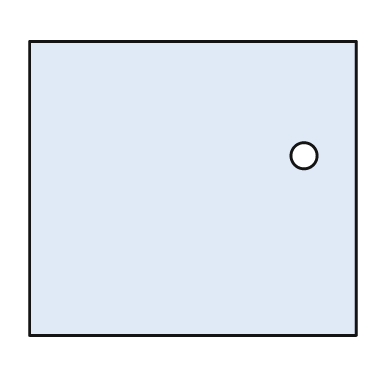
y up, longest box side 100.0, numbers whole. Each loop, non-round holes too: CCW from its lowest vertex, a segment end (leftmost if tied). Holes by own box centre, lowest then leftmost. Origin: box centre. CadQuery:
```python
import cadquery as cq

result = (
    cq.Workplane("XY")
    .moveTo(-50.0, -45.0)
    .lineTo(50.0, -45.0)
    .lineTo(50.0, 45.0)
    .lineTo(-50.0, 45.0)
    .close()
    .moveTo(34.0, 10.0)
    .circle(4.0)
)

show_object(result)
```